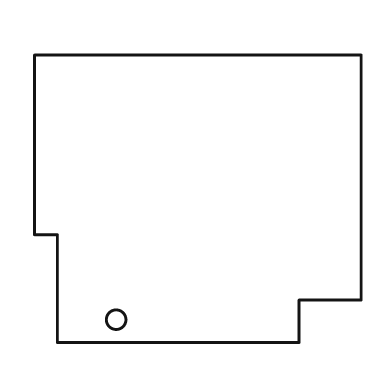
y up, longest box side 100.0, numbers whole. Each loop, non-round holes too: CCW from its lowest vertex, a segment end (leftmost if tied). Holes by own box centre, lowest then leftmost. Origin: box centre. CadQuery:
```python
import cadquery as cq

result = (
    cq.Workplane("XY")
    .moveTo(-43.0, -44.0)
    .lineTo(31.0, -44.0)
    .lineTo(31.0, -31.0)
    .lineTo(50.0, -31.0)
    .lineTo(50.0, 44.0)
    .lineTo(-50.0, 44.0)
    .lineTo(-50.0, -11.0)
    .lineTo(-43.0, -11.0)
    .close()
    .moveTo(-25.0, -37.0)
    .circle(3.0)
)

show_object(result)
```